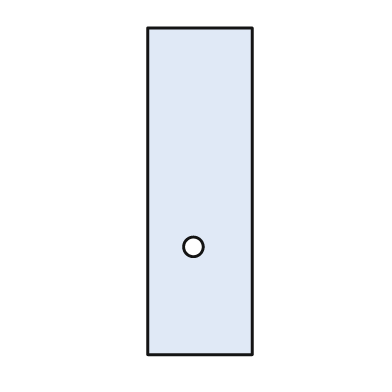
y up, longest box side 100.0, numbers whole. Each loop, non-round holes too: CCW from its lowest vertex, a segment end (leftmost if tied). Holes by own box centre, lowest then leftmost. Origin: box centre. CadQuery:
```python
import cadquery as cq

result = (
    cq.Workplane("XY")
    .moveTo(-16.0, -50.0)
    .lineTo(16.0, -50.0)
    .lineTo(16.0, 50.0)
    .lineTo(-16.0, 50.0)
    .close()
    .moveTo(-2.0, -17.0)
    .circle(3.0)
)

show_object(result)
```